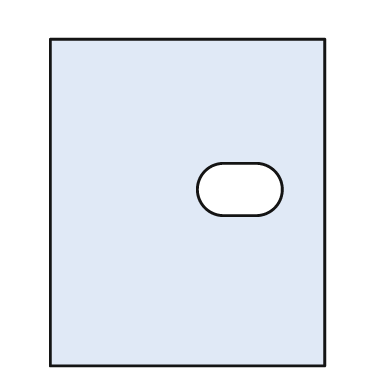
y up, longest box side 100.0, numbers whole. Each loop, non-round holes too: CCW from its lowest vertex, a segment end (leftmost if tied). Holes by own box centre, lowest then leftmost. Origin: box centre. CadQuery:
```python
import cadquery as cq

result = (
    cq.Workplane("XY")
    .moveTo(-42.0, -50.0)
    .lineTo(42.0, -50.0)
    .lineTo(42.0, 50.0)
    .lineTo(-42.0, 50.0)
    .close()
    .moveTo(11.0, -4.0)
    .lineTo(21.0, -4.0)
    .threePointArc((29.0, 4.0), (21.0, 12.0))
    .lineTo(11.0, 12.0)
    .threePointArc((3.0, 4.0), (11.0, -4.0))
    .close()
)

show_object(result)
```